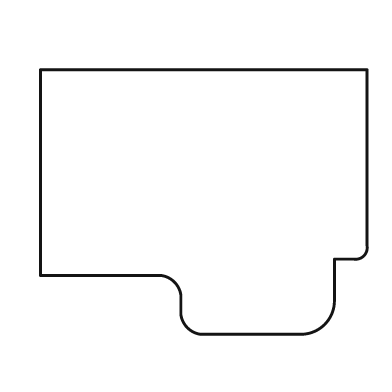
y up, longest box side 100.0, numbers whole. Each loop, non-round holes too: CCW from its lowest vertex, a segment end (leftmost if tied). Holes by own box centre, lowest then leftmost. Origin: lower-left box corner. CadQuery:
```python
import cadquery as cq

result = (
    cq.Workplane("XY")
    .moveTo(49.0, 0.0)
    .lineTo(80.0, 0.0)
    .threePointArc((87.0, 3.0), (90.0, 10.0))
    .lineTo(90.0, 23.0)
    .lineTo(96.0, 23.0)
    .threePointArc((99.0, 24.0), (100.0, 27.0))
    .lineTo(100.0, 81.0)
    .lineTo(0.0, 81.0)
    .lineTo(0.0, 18.0)
    .lineTo(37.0, 18.0)
    .threePointArc((41.0, 16.0), (43.0, 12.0))
    .lineTo(43.0, 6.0)
    .threePointArc((45.0, 2.0), (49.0, 0.0))
    .close()
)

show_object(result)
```